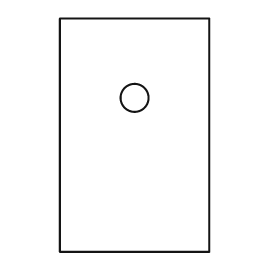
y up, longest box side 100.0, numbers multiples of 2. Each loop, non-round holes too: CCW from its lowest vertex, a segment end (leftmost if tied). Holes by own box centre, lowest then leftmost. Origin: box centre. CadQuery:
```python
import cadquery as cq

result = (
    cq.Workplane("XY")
    .moveTo(-32.0, -50.0)
    .lineTo(32.0, -50.0)
    .lineTo(32.0, 50.0)
    .lineTo(-32.0, 50.0)
    .close()
    .moveTo(0.0, 16.0)
    .circle(6.0)
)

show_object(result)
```